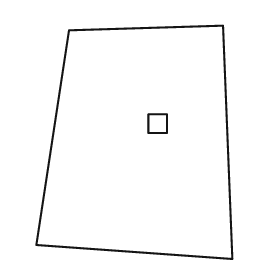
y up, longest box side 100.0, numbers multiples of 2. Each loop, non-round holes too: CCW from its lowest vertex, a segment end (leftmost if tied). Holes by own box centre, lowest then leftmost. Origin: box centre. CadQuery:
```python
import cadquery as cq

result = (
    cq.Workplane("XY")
    .moveTo(42.0, -50.0)
    .lineTo(38.0, 50.0)
    .lineTo(-28.0, 48.0)
    .lineTo(-42.0, -44.0)
    .close()
    .moveTo(6.0, 4.0)
    .lineTo(14.0, 4.0)
    .lineTo(14.0, 12.0)
    .lineTo(6.0, 12.0)
    .close()
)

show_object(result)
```